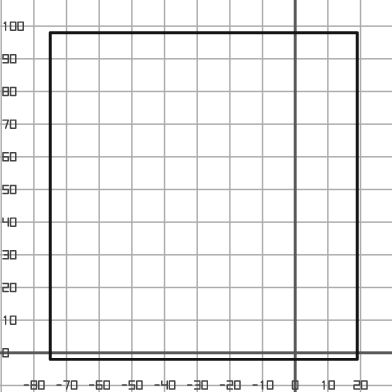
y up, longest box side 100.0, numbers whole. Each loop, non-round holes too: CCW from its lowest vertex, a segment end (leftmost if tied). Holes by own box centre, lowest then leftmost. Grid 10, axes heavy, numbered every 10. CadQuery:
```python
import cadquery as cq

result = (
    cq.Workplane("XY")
    .moveTo(-75.0, -2.0)
    .lineTo(19.0, -2.0)
    .lineTo(19.0, 98.0)
    .lineTo(-75.0, 98.0)
    .close()
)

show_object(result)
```